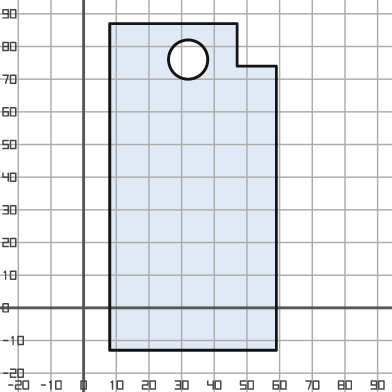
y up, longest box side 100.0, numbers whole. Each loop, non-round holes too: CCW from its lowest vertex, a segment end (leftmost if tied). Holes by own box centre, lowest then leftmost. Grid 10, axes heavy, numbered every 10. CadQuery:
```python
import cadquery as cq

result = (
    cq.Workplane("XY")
    .moveTo(8.0, -13.0)
    .lineTo(59.0, -13.0)
    .lineTo(59.0, 74.0)
    .lineTo(47.0, 74.0)
    .lineTo(47.0, 87.0)
    .lineTo(8.0, 87.0)
    .close()
    .moveTo(32.0, 76.0)
    .circle(6.0)
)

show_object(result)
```